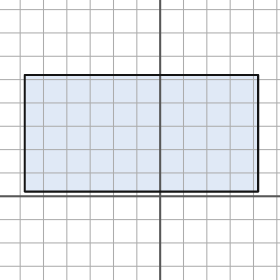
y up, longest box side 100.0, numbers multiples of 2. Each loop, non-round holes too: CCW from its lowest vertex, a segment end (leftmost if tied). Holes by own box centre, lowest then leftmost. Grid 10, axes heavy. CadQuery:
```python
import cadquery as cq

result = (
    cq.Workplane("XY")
    .moveTo(-58.0, 2.0)
    .lineTo(42.0, 2.0)
    .lineTo(42.0, 52.0)
    .lineTo(-58.0, 52.0)
    .close()
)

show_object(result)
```